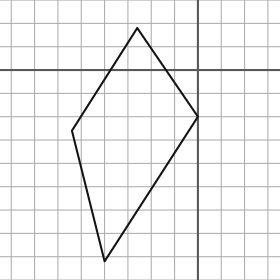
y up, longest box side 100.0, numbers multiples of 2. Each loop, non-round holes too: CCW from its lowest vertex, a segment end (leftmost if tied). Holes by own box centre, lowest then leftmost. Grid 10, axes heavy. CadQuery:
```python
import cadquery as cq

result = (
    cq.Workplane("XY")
    .moveTo(-40.0, -82.0)
    .lineTo(0.0, -20.0)
    .lineTo(-26.0, 18.0)
    .lineTo(-54.0, -26.0)
    .close()
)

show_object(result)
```